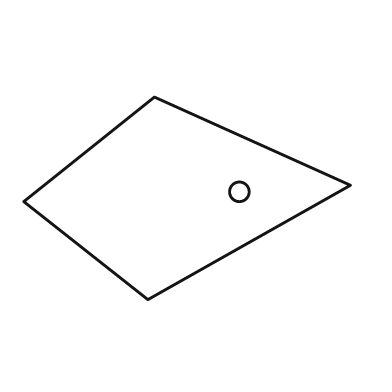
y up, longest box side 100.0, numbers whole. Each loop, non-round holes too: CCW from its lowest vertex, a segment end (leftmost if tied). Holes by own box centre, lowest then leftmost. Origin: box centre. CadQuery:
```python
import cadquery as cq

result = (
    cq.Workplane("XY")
    .moveTo(-12.0, -31.0)
    .lineTo(50.0, 4.0)
    .lineTo(-10.0, 31.0)
    .lineTo(-50.0, -1.0)
    .close()
    .moveTo(16.0, 2.0)
    .circle(3.0)
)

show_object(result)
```